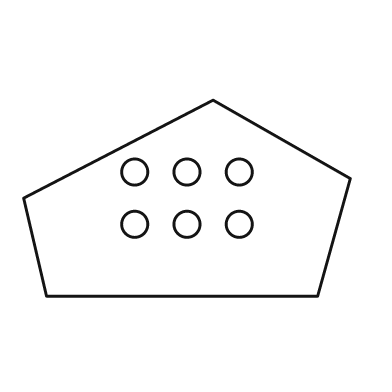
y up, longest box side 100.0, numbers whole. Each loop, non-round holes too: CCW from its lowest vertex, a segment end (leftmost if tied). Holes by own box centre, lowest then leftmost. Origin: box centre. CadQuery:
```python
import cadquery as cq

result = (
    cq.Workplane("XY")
    .moveTo(-43.0, -30.0)
    .lineTo(40.0, -30.0)
    .lineTo(50.0, 6.0)
    .lineTo(8.0, 30.0)
    .lineTo(-50.0, 0.0)
    .close()
    .moveTo(-16.0, -8.0)
    .circle(4.0)
    .moveTo(0.0, -8.0)
    .circle(4.0)
    .moveTo(16.0, -8.0)
    .circle(4.0)
    .moveTo(-16.0, 8.0)
    .circle(4.0)
    .moveTo(0.0, 8.0)
    .circle(4.0)
    .moveTo(16.0, 8.0)
    .circle(4.0)
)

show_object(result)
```